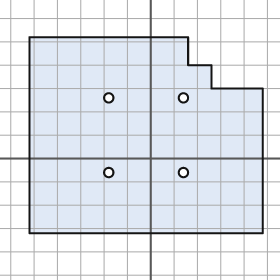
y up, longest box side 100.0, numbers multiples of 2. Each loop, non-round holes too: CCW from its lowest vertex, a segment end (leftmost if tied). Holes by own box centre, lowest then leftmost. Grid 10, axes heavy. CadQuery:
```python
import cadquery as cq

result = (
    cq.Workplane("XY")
    .moveTo(-52.0, -32.0)
    .lineTo(48.0, -32.0)
    .lineTo(48.0, 30.0)
    .lineTo(26.0, 30.0)
    .lineTo(26.0, 40.0)
    .lineTo(16.0, 40.0)
    .lineTo(16.0, 52.0)
    .lineTo(-52.0, 52.0)
    .close()
    .moveTo(-18.0, -6.0)
    .circle(2.0)
    .moveTo(14.0, -6.0)
    .circle(2.0)
    .moveTo(-18.0, 26.0)
    .circle(2.0)
    .moveTo(14.0, 26.0)
    .circle(2.0)
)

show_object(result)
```